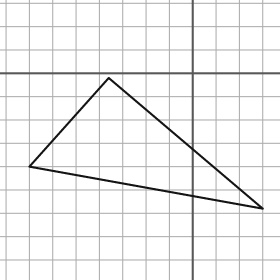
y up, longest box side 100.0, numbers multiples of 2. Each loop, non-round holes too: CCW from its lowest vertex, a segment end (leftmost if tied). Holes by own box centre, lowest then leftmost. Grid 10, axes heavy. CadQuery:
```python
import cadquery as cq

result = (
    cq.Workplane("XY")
    .moveTo(30.0, -58.0)
    .lineTo(-36.0, -2.0)
    .lineTo(-70.0, -40.0)
    .close()
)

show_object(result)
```